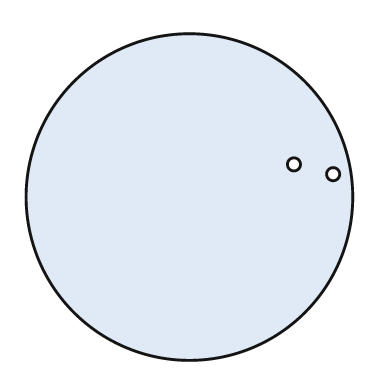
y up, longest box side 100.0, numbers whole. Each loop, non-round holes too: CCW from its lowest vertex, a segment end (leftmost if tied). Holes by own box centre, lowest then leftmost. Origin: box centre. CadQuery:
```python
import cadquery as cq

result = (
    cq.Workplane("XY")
    .moveTo(0.0, 0.0)
    .circle(50.0)
    .moveTo(44.0, 7.0)
    .circle(2.0)
    .moveTo(32.0, 10.0)
    .circle(2.0)
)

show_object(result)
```